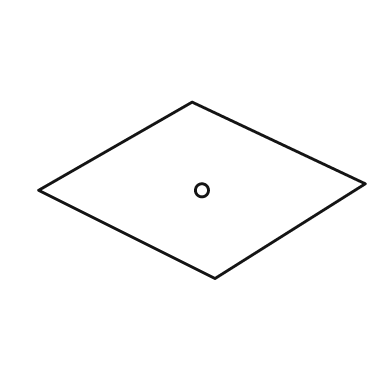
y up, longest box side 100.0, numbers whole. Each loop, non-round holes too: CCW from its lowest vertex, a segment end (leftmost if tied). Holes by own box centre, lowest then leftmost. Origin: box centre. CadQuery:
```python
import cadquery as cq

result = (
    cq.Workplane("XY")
    .moveTo(4.0, -27.0)
    .lineTo(50.0, 2.0)
    .lineTo(-3.0, 27.0)
    .lineTo(-50.0, 0.0)
    .close()
    .moveTo(0.0, 0.0)
    .circle(2.0)
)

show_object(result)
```